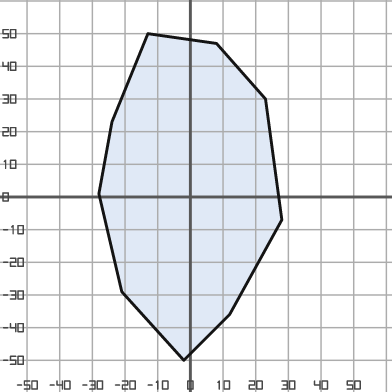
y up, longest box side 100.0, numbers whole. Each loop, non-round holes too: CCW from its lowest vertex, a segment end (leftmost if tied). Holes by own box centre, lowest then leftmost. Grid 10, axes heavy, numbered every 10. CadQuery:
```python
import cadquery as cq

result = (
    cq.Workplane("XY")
    .moveTo(-2.0, -50.0)
    .lineTo(12.0, -36.0)
    .lineTo(28.0, -7.0)
    .lineTo(23.0, 30.0)
    .lineTo(8.0, 47.0)
    .lineTo(-13.0, 50.0)
    .lineTo(-24.0, 23.0)
    .lineTo(-28.0, 1.0)
    .lineTo(-21.0, -29.0)
    .close()
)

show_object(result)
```